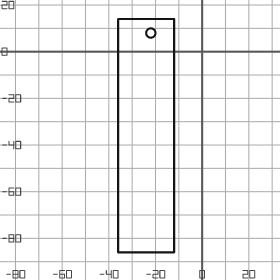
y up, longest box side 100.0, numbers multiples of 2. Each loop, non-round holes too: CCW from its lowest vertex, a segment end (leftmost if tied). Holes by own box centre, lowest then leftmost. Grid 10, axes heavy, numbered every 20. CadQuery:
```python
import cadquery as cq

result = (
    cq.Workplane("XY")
    .moveTo(-36.0, -86.0)
    .lineTo(-12.0, -86.0)
    .lineTo(-12.0, 14.0)
    .lineTo(-36.0, 14.0)
    .close()
    .moveTo(-22.0, 8.0)
    .circle(2.0)
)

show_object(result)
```